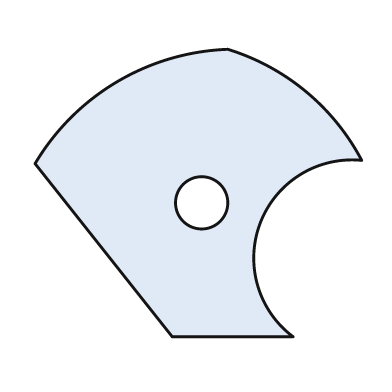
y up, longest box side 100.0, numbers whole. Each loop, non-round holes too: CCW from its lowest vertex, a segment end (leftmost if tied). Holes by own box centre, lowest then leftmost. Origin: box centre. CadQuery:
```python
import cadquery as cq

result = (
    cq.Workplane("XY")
    .moveTo(-8.0, -44.0)
    .lineTo(29.0, -44.0)
    .threePointArc((19.0, -9.0), (50.0, 10.0))
    .threePointArc((33.0, 31.0), (9.0, 44.0))
    .threePointArc((-25.0, 34.0), (-50.0, 9.0))
    .close()
    .moveTo(1.0, -3.0)
    .circle(8.0)
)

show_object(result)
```